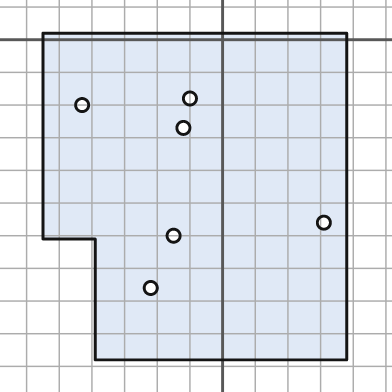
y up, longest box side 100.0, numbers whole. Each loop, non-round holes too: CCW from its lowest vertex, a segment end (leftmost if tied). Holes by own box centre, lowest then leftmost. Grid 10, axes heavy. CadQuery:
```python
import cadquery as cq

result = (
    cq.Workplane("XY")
    .moveTo(-39.0, -98.0)
    .lineTo(38.0, -98.0)
    .lineTo(38.0, 2.0)
    .lineTo(-55.0, 2.0)
    .lineTo(-55.0, -61.0)
    .lineTo(-39.0, -61.0)
    .close()
    .moveTo(-22.0, -76.0)
    .circle(2.0)
    .moveTo(-15.0, -60.0)
    .circle(2.0)
    .moveTo(31.0, -56.0)
    .circle(2.0)
    .moveTo(-12.0, -27.0)
    .circle(2.0)
    .moveTo(-43.0, -20.0)
    .circle(2.0)
    .moveTo(-10.0, -18.0)
    .circle(2.0)
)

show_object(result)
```